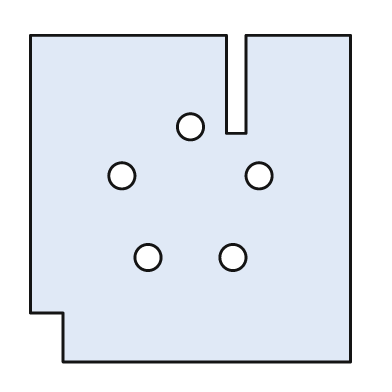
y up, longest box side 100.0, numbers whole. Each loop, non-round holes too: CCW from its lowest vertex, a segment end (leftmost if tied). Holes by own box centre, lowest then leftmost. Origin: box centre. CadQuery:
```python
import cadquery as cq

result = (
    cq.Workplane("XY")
    .moveTo(-39.0, -50.0)
    .lineTo(49.0, -50.0)
    .lineTo(49.0, 50.0)
    .lineTo(17.0, 50.0)
    .lineTo(17.0, 20.0)
    .lineTo(11.0, 20.0)
    .lineTo(11.0, 50.0)
    .lineTo(-49.0, 50.0)
    .lineTo(-49.0, -35.0)
    .lineTo(-39.0, -35.0)
    .close()
    .moveTo(-13.0, -18.0)
    .circle(4.0)
    .moveTo(13.0, -18.0)
    .circle(4.0)
    .moveTo(-21.0, 7.0)
    .circle(4.0)
    .moveTo(21.0, 7.0)
    .circle(4.0)
    .moveTo(0.0, 22.0)
    .circle(4.0)
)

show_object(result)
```